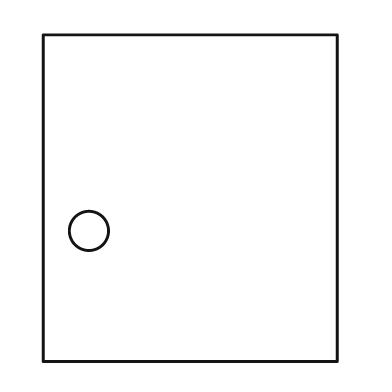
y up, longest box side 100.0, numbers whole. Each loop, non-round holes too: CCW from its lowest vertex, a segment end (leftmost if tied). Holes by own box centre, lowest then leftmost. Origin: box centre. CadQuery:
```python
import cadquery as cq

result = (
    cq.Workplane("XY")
    .moveTo(-45.0, -50.0)
    .lineTo(45.0, -50.0)
    .lineTo(45.0, 50.0)
    .lineTo(-45.0, 50.0)
    .close()
    .moveTo(-31.0, -10.0)
    .circle(6.0)
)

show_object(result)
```